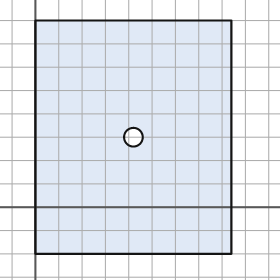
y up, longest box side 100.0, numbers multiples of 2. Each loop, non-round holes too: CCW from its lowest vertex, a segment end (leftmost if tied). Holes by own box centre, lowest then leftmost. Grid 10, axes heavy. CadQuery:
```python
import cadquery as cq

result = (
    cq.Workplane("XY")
    .moveTo(0.0, -20.0)
    .lineTo(84.0, -20.0)
    .lineTo(84.0, 80.0)
    .lineTo(0.0, 80.0)
    .close()
    .moveTo(42.0, 30.0)
    .circle(4.0)
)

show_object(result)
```